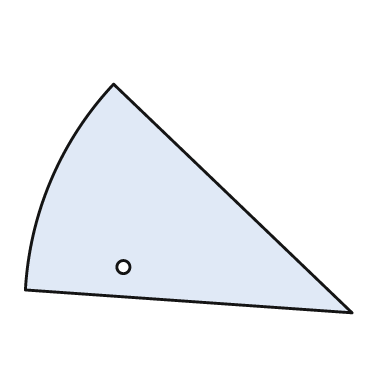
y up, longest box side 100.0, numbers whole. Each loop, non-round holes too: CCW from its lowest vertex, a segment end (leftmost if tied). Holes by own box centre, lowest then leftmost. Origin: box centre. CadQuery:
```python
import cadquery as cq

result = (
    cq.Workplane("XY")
    .moveTo(50.0, -35.0)
    .lineTo(-23.0, 35.0)
    .threePointArc((-42.0, 6.0), (-50.0, -28.0))
    .close()
    .moveTo(-20.0, -21.0)
    .circle(2.0)
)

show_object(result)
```